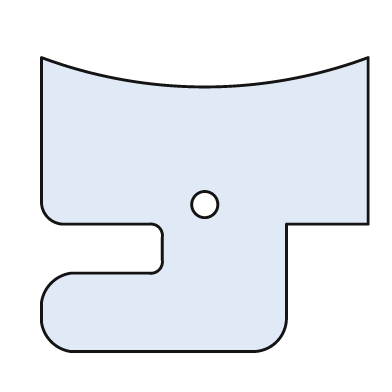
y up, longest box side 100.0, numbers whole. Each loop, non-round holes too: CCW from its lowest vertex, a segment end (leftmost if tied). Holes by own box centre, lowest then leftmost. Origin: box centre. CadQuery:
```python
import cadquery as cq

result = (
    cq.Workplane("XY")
    .moveTo(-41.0, -45.0)
    .lineTo(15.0, -45.0)
    .threePointArc((22.0, -42.0), (25.0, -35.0))
    .lineTo(25.0, -6.0)
    .lineTo(50.0, -6.0)
    .lineTo(50.0, 45.0)
    .threePointArc((0.0, 36.0), (-50.0, 45.0))
    .lineTo(-50.0, 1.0)
    .threePointArc((-48.0, -4.0), (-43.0, -6.0))
    .lineTo(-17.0, -6.0)
    .threePointArc((-14.0, -7.0), (-13.0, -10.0))
    .lineTo(-13.0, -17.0)
    .threePointArc((-14.0, -20.0), (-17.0, -21.0))
    .lineTo(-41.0, -21.0)
    .threePointArc((-47.0, -24.0), (-50.0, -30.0))
    .lineTo(-50.0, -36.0)
    .threePointArc((-47.0, -42.0), (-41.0, -45.0))
    .close()
    .moveTo(0.0, 0.0)
    .circle(4.0)
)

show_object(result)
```